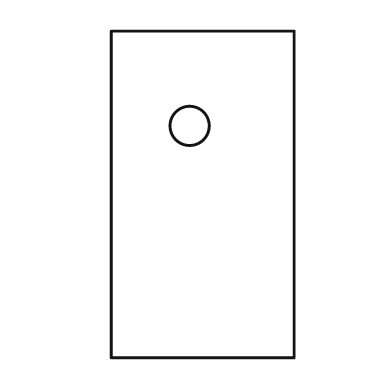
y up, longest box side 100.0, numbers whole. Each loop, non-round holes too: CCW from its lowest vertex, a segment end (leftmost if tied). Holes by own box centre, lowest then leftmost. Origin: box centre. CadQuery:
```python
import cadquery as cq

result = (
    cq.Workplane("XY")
    .moveTo(-28.0, -50.0)
    .lineTo(28.0, -50.0)
    .lineTo(28.0, 50.0)
    .lineTo(-28.0, 50.0)
    .close()
    .moveTo(-4.0, 21.0)
    .circle(6.0)
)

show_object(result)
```